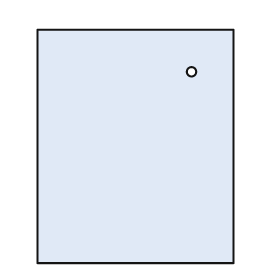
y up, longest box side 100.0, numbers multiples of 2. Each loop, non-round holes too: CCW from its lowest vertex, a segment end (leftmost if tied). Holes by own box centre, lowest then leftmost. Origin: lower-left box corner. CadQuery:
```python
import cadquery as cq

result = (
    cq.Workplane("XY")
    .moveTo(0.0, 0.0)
    .lineTo(84.0, 0.0)
    .lineTo(84.0, 100.0)
    .lineTo(0.0, 100.0)
    .close()
    .moveTo(66.0, 82.0)
    .circle(2.0)
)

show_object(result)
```